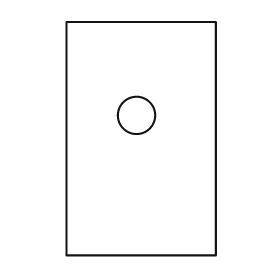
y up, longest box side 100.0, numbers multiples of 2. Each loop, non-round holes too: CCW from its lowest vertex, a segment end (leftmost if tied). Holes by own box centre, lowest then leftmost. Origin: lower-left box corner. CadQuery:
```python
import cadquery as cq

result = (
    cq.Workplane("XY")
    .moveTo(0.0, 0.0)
    .lineTo(64.0, 0.0)
    .lineTo(64.0, 100.0)
    .lineTo(0.0, 100.0)
    .close()
    .moveTo(30.0, 60.0)
    .circle(8.0)
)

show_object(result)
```